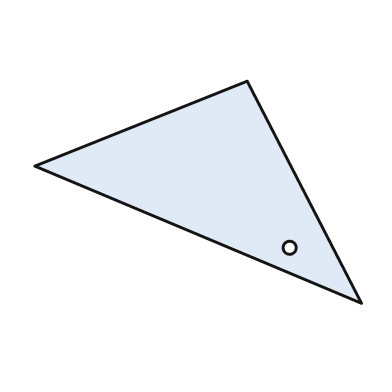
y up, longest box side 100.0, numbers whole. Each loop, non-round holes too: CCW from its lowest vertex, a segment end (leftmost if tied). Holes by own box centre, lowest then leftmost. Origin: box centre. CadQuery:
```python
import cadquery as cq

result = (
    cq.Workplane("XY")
    .moveTo(50.0, -34.0)
    .lineTo(15.0, 34.0)
    .lineTo(-50.0, 8.0)
    .close()
    .moveTo(28.0, -17.0)
    .circle(2.0)
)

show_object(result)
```